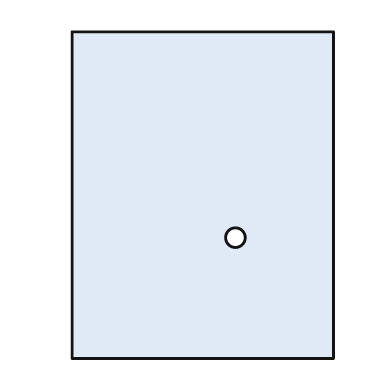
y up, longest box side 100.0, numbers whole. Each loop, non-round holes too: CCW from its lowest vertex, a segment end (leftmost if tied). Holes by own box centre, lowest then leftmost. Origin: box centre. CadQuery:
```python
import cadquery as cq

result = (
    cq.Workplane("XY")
    .moveTo(-40.0, -50.0)
    .lineTo(40.0, -50.0)
    .lineTo(40.0, 50.0)
    .lineTo(-40.0, 50.0)
    .close()
    .moveTo(10.0, -13.0)
    .circle(3.0)
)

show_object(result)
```